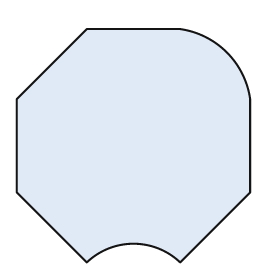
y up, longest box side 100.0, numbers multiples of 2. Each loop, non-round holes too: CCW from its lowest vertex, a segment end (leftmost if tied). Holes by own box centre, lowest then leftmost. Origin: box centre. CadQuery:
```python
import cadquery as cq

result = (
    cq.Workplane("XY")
    .moveTo(-20.0, -50.0)
    .threePointArc((0.0, -42.0), (20.0, -50.0))
    .lineTo(50.0, -20.0)
    .lineTo(50.0, 20.0)
    .threePointArc((40.0, 40.0), (20.0, 50.0))
    .lineTo(-20.0, 50.0)
    .lineTo(-50.0, 20.0)
    .lineTo(-50.0, -20.0)
    .close()
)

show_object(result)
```